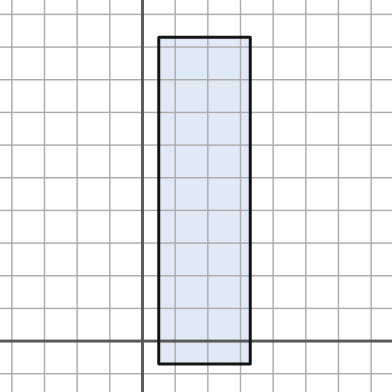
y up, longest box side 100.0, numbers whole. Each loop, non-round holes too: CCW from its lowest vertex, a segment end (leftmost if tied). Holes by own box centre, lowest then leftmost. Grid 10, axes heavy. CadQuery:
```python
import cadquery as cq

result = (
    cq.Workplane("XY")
    .moveTo(5.0, -7.0)
    .lineTo(33.0, -7.0)
    .lineTo(33.0, 93.0)
    .lineTo(5.0, 93.0)
    .close()
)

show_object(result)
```